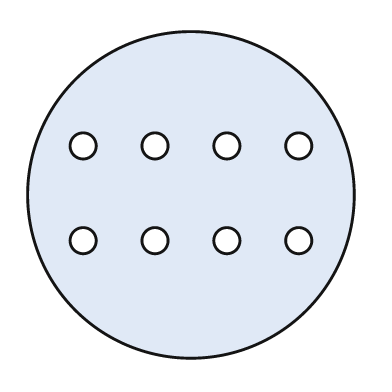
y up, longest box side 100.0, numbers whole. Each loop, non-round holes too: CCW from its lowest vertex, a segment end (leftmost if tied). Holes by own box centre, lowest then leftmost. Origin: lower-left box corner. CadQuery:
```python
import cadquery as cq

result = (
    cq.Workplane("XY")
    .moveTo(50.0, 50.0)
    .circle(50.0)
    .moveTo(17.0, 36.0)
    .circle(4.0)
    .moveTo(39.0, 36.0)
    .circle(4.0)
    .moveTo(61.0, 36.0)
    .circle(4.0)
    .moveTo(83.0, 36.0)
    .circle(4.0)
    .moveTo(17.0, 65.0)
    .circle(4.0)
    .moveTo(39.0, 65.0)
    .circle(4.0)
    .moveTo(61.0, 65.0)
    .circle(4.0)
    .moveTo(83.0, 65.0)
    .circle(4.0)
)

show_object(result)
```